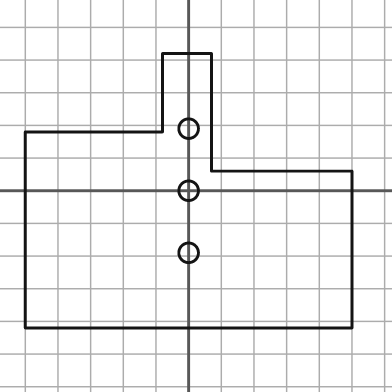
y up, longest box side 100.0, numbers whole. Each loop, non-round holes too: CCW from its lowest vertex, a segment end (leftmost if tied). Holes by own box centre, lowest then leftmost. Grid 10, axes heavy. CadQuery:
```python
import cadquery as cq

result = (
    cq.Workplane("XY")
    .moveTo(-50.0, -42.0)
    .lineTo(50.0, -42.0)
    .lineTo(50.0, 6.0)
    .lineTo(7.0, 6.0)
    .lineTo(7.0, 42.0)
    .lineTo(-8.0, 42.0)
    .lineTo(-8.0, 18.0)
    .lineTo(-50.0, 18.0)
    .close()
    .moveTo(0.0, -19.0)
    .circle(3.0)
    .moveTo(0.0, 0.0)
    .circle(3.0)
    .moveTo(0.0, 19.0)
    .circle(3.0)
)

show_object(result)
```